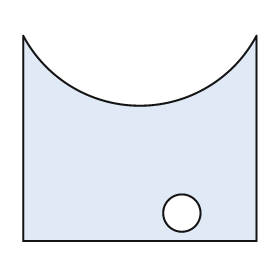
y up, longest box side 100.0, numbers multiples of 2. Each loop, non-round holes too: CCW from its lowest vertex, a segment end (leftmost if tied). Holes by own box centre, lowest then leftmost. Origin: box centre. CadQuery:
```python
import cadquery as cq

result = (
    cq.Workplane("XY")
    .moveTo(-50.0, -44.0)
    .lineTo(50.0, -44.0)
    .lineTo(50.0, 44.0)
    .threePointArc((0.0, 14.0), (-50.0, 44.0))
    .close()
    .moveTo(18.0, -32.0)
    .circle(8.0)
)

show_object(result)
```